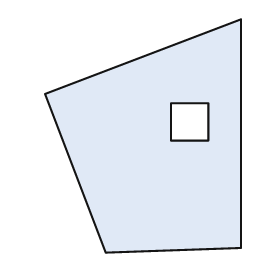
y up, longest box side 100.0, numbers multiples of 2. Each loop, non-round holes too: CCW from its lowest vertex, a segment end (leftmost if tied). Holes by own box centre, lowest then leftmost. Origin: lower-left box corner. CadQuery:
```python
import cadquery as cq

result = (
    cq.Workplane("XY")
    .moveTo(26.0, 0.0)
    .lineTo(84.0, 2.0)
    .lineTo(84.0, 100.0)
    .lineTo(0.0, 68.0)
    .close()
    .moveTo(54.0, 48.0)
    .lineTo(70.0, 48.0)
    .lineTo(70.0, 64.0)
    .lineTo(54.0, 64.0)
    .close()
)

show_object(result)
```